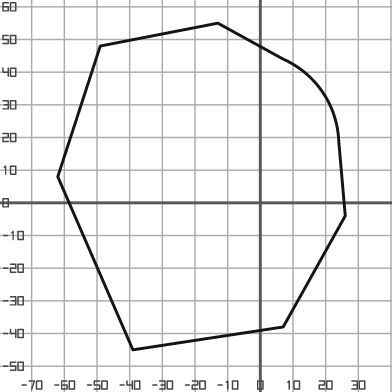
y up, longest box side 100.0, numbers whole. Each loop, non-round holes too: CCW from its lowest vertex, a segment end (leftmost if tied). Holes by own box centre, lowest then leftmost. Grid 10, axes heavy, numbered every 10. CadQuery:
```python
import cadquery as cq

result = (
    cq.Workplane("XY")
    .moveTo(-39.0, -45.0)
    .lineTo(7.0, -38.0)
    .lineTo(26.0, -4.0)
    .lineTo(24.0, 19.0)
    .threePointArc((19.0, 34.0), (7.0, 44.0))
    .lineTo(-13.0, 55.0)
    .lineTo(-49.0, 48.0)
    .lineTo(-62.0, 8.0)
    .close()
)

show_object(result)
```